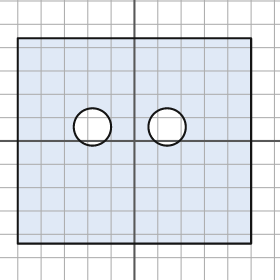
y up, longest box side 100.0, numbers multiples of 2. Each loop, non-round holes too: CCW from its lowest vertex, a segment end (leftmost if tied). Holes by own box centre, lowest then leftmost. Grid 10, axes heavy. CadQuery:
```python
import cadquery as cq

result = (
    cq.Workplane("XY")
    .moveTo(-50.0, -44.0)
    .lineTo(50.0, -44.0)
    .lineTo(50.0, 44.0)
    .lineTo(-50.0, 44.0)
    .close()
    .moveTo(-18.0, 6.0)
    .circle(8.0)
    .moveTo(14.0, 6.0)
    .circle(8.0)
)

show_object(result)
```